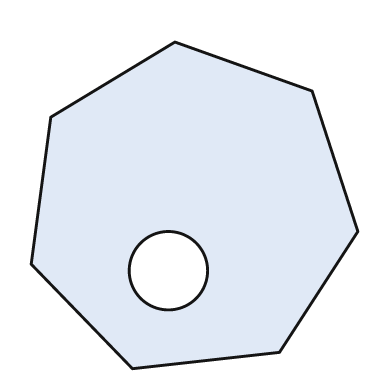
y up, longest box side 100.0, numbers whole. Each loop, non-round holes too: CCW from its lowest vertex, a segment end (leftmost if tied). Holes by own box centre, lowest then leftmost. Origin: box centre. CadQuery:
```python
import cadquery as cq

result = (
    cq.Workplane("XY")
    .moveTo(-19.0, -50.0)
    .lineTo(26.0, -45.0)
    .lineTo(50.0, -8.0)
    .lineTo(36.0, 35.0)
    .lineTo(-6.0, 50.0)
    .lineTo(-44.0, 27.0)
    .lineTo(-50.0, -18.0)
    .close()
    .moveTo(-8.0, -20.0)
    .circle(12.0)
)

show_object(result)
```